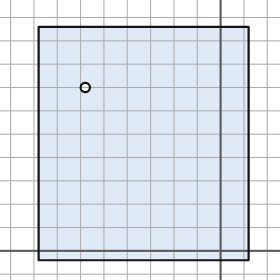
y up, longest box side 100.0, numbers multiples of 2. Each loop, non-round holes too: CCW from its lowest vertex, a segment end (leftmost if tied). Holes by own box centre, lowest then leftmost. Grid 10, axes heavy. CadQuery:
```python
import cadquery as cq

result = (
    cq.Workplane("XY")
    .moveTo(-78.0, -4.0)
    .lineTo(12.0, -4.0)
    .lineTo(12.0, 96.0)
    .lineTo(-78.0, 96.0)
    .close()
    .moveTo(-58.0, 70.0)
    .circle(2.0)
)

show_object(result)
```